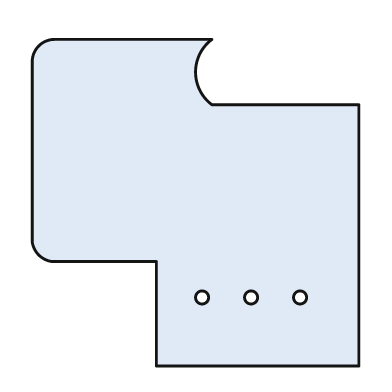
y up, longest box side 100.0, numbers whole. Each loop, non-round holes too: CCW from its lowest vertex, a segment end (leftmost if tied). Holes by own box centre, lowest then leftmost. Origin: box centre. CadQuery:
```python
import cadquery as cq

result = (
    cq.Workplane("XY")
    .moveTo(-12.0, -50.0)
    .lineTo(50.0, -50.0)
    .lineTo(50.0, 30.0)
    .lineTo(5.0, 30.0)
    .threePointArc((0.0, 40.0), (5.0, 50.0))
    .lineTo(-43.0, 50.0)
    .threePointArc((-48.0, 48.0), (-50.0, 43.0))
    .lineTo(-50.0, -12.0)
    .threePointArc((-48.0, -16.0), (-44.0, -18.0))
    .lineTo(-12.0, -18.0)
    .close()
    .moveTo(2.0, -29.0)
    .circle(2.0)
    .moveTo(17.0, -29.0)
    .circle(2.0)
    .moveTo(32.0, -29.0)
    .circle(2.0)
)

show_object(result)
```